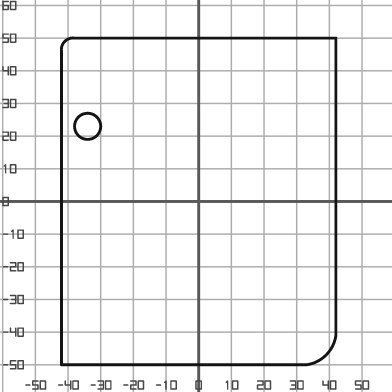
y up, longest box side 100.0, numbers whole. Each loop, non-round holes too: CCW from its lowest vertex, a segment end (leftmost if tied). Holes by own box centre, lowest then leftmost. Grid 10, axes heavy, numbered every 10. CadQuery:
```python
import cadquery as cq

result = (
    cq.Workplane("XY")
    .moveTo(-42.0, -50.0)
    .lineTo(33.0, -50.0)
    .threePointArc((39.0, -47.0), (42.0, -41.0))
    .lineTo(42.0, 50.0)
    .lineTo(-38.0, 50.0)
    .threePointArc((-41.0, 49.0), (-42.0, 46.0))
    .close()
    .moveTo(-34.0, 23.0)
    .circle(4.0)
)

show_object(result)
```